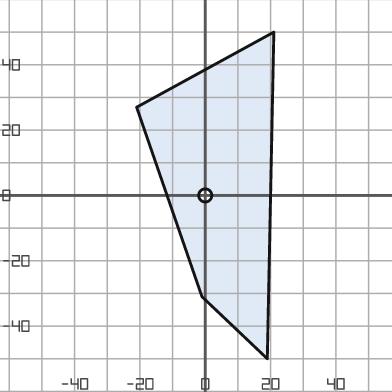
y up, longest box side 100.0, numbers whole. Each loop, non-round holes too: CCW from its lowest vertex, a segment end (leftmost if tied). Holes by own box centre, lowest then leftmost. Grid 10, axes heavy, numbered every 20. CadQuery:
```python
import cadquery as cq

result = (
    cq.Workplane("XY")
    .moveTo(19.0, -50.0)
    .lineTo(21.0, 50.0)
    .lineTo(-21.0, 27.0)
    .lineTo(-1.0, -31.0)
    .close()
    .moveTo(0.0, 0.0)
    .circle(2.0)
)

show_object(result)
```